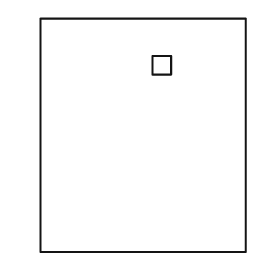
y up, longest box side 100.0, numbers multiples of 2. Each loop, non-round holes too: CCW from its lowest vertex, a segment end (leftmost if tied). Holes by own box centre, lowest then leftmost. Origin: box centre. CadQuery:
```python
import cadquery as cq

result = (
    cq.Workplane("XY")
    .moveTo(-44.0, -50.0)
    .lineTo(44.0, -50.0)
    .lineTo(44.0, 50.0)
    .lineTo(-44.0, 50.0)
    .close()
    .moveTo(4.0, 26.0)
    .lineTo(12.0, 26.0)
    .lineTo(12.0, 34.0)
    .lineTo(4.0, 34.0)
    .close()
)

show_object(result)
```